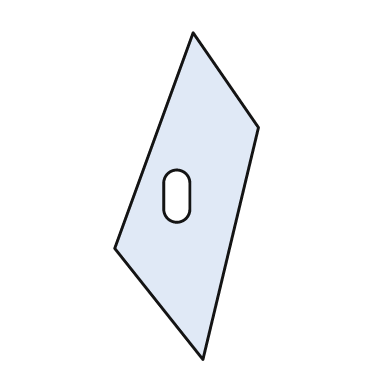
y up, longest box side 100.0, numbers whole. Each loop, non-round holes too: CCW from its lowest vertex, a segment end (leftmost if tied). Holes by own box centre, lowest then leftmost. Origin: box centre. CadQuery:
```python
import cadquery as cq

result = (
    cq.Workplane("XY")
    .moveTo(5.0, -50.0)
    .lineTo(22.0, 21.0)
    .lineTo(2.0, 50.0)
    .lineTo(-22.0, -16.0)
    .close()
    .moveTo(-7.0, -4.0)
    .threePointArc((-3.0, -8.0), (1.0, -4.0))
    .lineTo(1.0, 4.0)
    .threePointArc((-3.0, 8.0), (-7.0, 4.0))
    .close()
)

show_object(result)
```